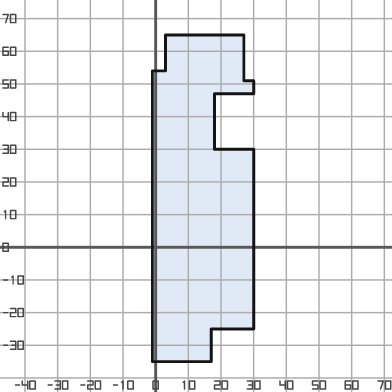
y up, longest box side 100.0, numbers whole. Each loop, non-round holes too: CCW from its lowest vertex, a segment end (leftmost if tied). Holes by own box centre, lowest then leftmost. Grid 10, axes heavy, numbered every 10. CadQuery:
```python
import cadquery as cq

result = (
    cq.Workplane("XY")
    .moveTo(-1.0, -35.0)
    .lineTo(17.0, -35.0)
    .lineTo(17.0, -25.0)
    .lineTo(30.0, -25.0)
    .lineTo(30.0, 30.0)
    .lineTo(18.0, 30.0)
    .lineTo(18.0, 47.0)
    .lineTo(30.0, 47.0)
    .lineTo(30.0, 51.0)
    .lineTo(27.0, 51.0)
    .lineTo(27.0, 65.0)
    .lineTo(3.0, 65.0)
    .lineTo(3.0, 54.0)
    .lineTo(-1.0, 54.0)
    .close()
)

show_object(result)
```